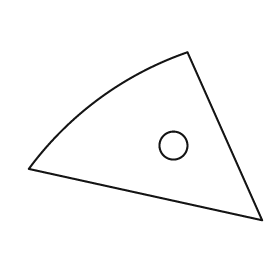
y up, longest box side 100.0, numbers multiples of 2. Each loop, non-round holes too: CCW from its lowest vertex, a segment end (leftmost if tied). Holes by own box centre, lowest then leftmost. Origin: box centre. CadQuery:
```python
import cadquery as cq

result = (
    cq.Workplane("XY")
    .moveTo(50.0, -36.0)
    .lineTo(18.0, 36.0)
    .threePointArc((-20.0, 16.0), (-50.0, -14.0))
    .close()
    .moveTo(12.0, -4.0)
    .circle(6.0)
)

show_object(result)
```